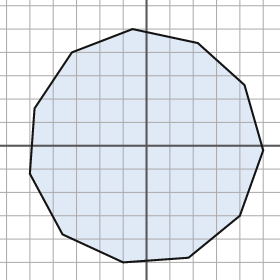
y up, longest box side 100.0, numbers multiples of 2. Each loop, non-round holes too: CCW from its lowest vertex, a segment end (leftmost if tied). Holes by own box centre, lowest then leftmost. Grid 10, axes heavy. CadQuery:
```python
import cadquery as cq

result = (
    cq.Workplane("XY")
    .moveTo(-10.0, -50.0)
    .lineTo(18.0, -48.0)
    .lineTo(40.0, -30.0)
    .lineTo(50.0, -2.0)
    .lineTo(42.0, 26.0)
    .lineTo(22.0, 44.0)
    .lineTo(-6.0, 50.0)
    .lineTo(-32.0, 40.0)
    .lineTo(-48.0, 16.0)
    .lineTo(-50.0, -12.0)
    .lineTo(-36.0, -38.0)
    .close()
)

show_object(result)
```